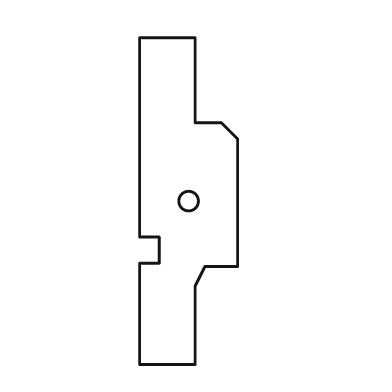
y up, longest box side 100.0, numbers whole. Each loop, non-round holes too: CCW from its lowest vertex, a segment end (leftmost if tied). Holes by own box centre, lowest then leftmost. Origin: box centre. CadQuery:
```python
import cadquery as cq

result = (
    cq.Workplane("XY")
    .moveTo(-15.0, -50.0)
    .lineTo(2.0, -50.0)
    .lineTo(2.0, -26.0)
    .lineTo(5.0, -20.0)
    .lineTo(15.0, -20.0)
    .lineTo(15.0, 19.0)
    .lineTo(10.0, 24.0)
    .lineTo(2.0, 24.0)
    .lineTo(2.0, 50.0)
    .lineTo(-15.0, 50.0)
    .lineTo(-15.0, -11.0)
    .lineTo(-9.0, -11.0)
    .lineTo(-9.0, -19.0)
    .lineTo(-15.0, -19.0)
    .close()
    .moveTo(0.0, 0.0)
    .circle(3.0)
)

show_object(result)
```